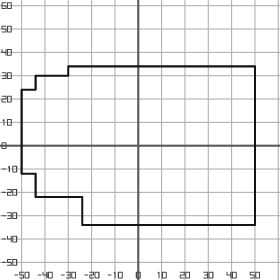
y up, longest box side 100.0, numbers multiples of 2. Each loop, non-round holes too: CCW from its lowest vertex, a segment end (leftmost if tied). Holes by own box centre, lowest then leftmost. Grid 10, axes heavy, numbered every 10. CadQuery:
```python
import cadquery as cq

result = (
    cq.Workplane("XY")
    .moveTo(-24.0, -34.0)
    .lineTo(50.0, -34.0)
    .lineTo(50.0, 34.0)
    .lineTo(-30.0, 34.0)
    .lineTo(-30.0, 30.0)
    .lineTo(-44.0, 30.0)
    .lineTo(-44.0, 24.0)
    .lineTo(-50.0, 24.0)
    .lineTo(-50.0, -12.0)
    .lineTo(-44.0, -12.0)
    .lineTo(-44.0, -22.0)
    .lineTo(-24.0, -22.0)
    .close()
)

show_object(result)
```